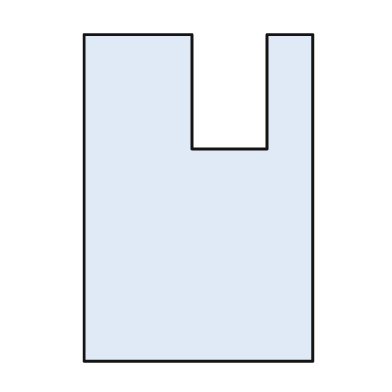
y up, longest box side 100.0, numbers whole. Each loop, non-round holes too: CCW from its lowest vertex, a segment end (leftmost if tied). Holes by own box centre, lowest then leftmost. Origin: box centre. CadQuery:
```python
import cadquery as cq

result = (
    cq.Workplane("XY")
    .moveTo(-35.0, -50.0)
    .lineTo(35.0, -50.0)
    .lineTo(35.0, 50.0)
    .lineTo(21.0, 50.0)
    .lineTo(21.0, 15.0)
    .lineTo(-2.0, 15.0)
    .lineTo(-2.0, 50.0)
    .lineTo(-35.0, 50.0)
    .close()
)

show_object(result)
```